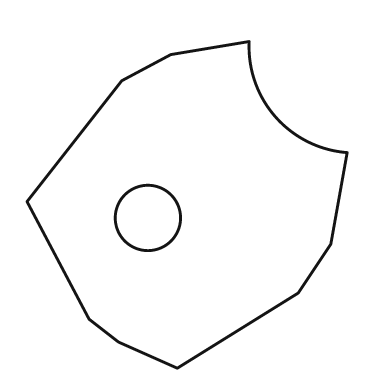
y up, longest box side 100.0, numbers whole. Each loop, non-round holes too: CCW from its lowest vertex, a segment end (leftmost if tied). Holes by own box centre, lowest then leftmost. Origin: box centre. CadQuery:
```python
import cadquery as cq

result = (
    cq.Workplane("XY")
    .moveTo(-3.0, -50.0)
    .lineTo(34.0, -27.0)
    .lineTo(44.0, -12.0)
    .lineTo(49.0, 16.0)
    .threePointArc((27.0, 27.0), (19.0, 50.0))
    .lineTo(-5.0, 46.0)
    .lineTo(-20.0, 38.0)
    .lineTo(-49.0, 1.0)
    .lineTo(-30.0, -35.0)
    .lineTo(-21.0, -42.0)
    .close()
    .moveTo(-12.0, -4.0)
    .circle(10.0)
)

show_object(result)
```